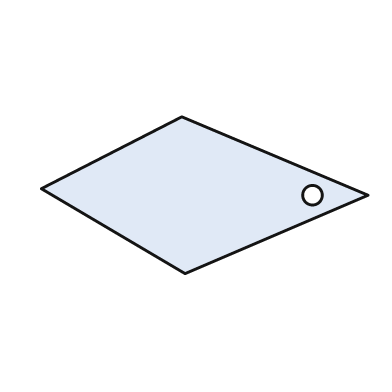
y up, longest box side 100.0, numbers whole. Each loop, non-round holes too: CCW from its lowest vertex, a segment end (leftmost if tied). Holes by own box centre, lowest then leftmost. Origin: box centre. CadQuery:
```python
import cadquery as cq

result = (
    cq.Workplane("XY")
    .moveTo(-6.0, -24.0)
    .lineTo(50.0, 0.0)
    .lineTo(-7.0, 24.0)
    .lineTo(-50.0, 2.0)
    .close()
    .moveTo(33.0, 0.0)
    .circle(3.0)
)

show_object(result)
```